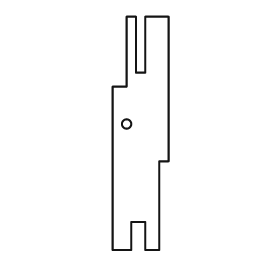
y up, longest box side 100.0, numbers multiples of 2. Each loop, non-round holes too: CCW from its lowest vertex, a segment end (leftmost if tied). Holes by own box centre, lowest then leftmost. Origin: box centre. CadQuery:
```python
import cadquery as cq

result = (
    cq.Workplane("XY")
    .moveTo(-12.0, -50.0)
    .lineTo(-4.0, -50.0)
    .lineTo(-4.0, -38.0)
    .lineTo(2.0, -38.0)
    .lineTo(2.0, -50.0)
    .lineTo(8.0, -50.0)
    .lineTo(8.0, -12.0)
    .lineTo(12.0, -12.0)
    .lineTo(12.0, 50.0)
    .lineTo(2.0, 50.0)
    .lineTo(2.0, 26.0)
    .lineTo(-2.0, 26.0)
    .lineTo(-2.0, 50.0)
    .lineTo(-6.0, 50.0)
    .lineTo(-6.0, 20.0)
    .lineTo(-12.0, 20.0)
    .close()
    .moveTo(-6.0, 4.0)
    .circle(2.0)
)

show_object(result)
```